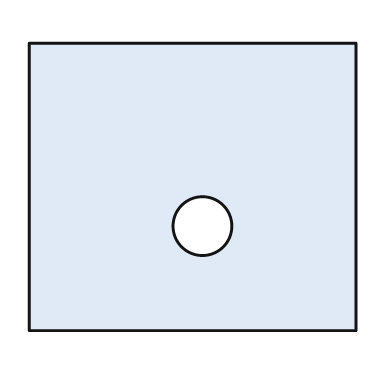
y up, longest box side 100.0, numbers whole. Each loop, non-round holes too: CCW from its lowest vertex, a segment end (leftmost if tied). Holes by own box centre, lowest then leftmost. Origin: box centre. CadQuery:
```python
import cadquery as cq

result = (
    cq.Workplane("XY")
    .moveTo(-50.0, -44.0)
    .lineTo(50.0, -44.0)
    .lineTo(50.0, 44.0)
    .lineTo(-50.0, 44.0)
    .close()
    .moveTo(3.0, -12.0)
    .circle(9.0)
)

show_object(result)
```